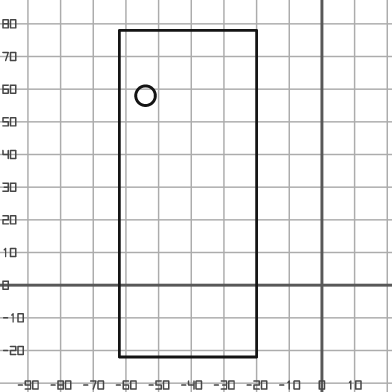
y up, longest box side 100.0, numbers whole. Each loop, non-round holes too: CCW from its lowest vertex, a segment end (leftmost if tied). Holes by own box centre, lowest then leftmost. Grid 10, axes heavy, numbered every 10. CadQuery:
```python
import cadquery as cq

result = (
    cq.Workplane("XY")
    .moveTo(-62.0, -22.0)
    .lineTo(-20.0, -22.0)
    .lineTo(-20.0, 78.0)
    .lineTo(-62.0, 78.0)
    .close()
    .moveTo(-54.0, 58.0)
    .circle(3.0)
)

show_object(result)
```